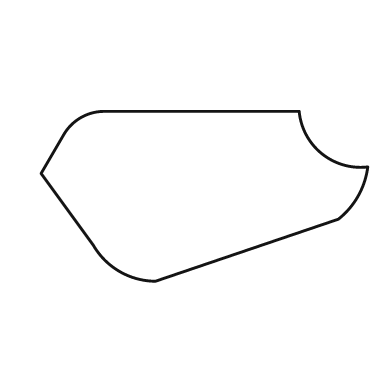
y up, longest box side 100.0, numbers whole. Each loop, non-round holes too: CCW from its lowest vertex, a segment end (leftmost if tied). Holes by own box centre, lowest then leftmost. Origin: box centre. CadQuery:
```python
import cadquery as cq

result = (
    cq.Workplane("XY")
    .moveTo(-15.0, -26.0)
    .lineTo(41.0, -7.0)
    .threePointArc((47.0, 0.0), (50.0, 9.0))
    .threePointArc((36.0, 13.0), (29.0, 26.0))
    .lineTo(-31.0, 26.0)
    .threePointArc((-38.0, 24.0), (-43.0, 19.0))
    .lineTo(-50.0, 7.0)
    .lineTo(-34.0, -15.0)
    .threePointArc((-26.0, -23.0), (-15.0, -26.0))
    .close()
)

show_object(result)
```